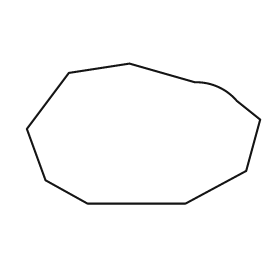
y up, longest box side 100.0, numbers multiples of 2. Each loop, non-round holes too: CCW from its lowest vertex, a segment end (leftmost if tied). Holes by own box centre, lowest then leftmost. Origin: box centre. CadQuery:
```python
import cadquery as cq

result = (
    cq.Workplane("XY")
    .moveTo(-24.0, -30.0)
    .lineTo(18.0, -30.0)
    .lineTo(44.0, -16.0)
    .lineTo(50.0, 6.0)
    .lineTo(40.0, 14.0)
    .threePointArc((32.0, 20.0), (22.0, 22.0))
    .lineTo(-6.0, 30.0)
    .lineTo(-32.0, 26.0)
    .lineTo(-50.0, 2.0)
    .lineTo(-42.0, -20.0)
    .close()
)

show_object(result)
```